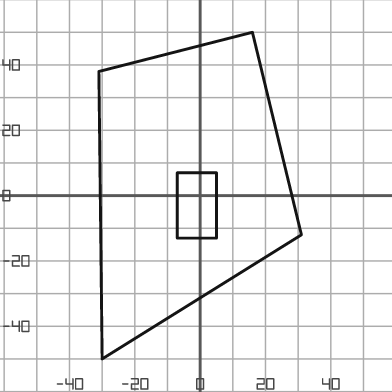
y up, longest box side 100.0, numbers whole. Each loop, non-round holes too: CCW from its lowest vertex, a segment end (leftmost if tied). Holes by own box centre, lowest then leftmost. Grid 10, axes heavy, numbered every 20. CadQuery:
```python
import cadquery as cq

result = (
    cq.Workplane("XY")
    .moveTo(-30.0, -50.0)
    .lineTo(31.0, -12.0)
    .lineTo(16.0, 50.0)
    .lineTo(-31.0, 38.0)
    .close()
    .moveTo(-7.0, -13.0)
    .lineTo(5.0, -13.0)
    .lineTo(5.0, 7.0)
    .lineTo(-7.0, 7.0)
    .close()
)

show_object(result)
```